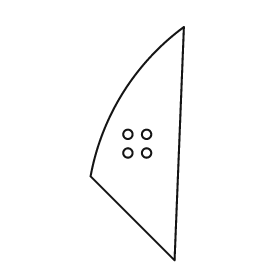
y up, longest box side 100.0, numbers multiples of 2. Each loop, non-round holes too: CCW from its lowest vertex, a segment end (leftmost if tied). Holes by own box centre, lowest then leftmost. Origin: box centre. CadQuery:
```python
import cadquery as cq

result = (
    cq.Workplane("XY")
    .moveTo(16.0, -50.0)
    .lineTo(20.0, 50.0)
    .threePointArc((-6.0, 22.0), (-20.0, -14.0))
    .close()
    .moveTo(-4.0, -4.0)
    .circle(2.0)
    .moveTo(4.0, -4.0)
    .circle(2.0)
    .moveTo(-4.0, 4.0)
    .circle(2.0)
    .moveTo(4.0, 4.0)
    .circle(2.0)
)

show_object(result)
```